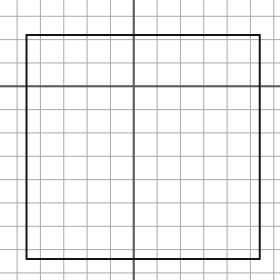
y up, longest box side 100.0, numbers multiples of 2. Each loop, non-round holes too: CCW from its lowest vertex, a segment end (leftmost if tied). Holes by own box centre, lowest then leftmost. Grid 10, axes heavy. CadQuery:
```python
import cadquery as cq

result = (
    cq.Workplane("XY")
    .moveTo(-46.0, -74.0)
    .lineTo(54.0, -74.0)
    .lineTo(54.0, 22.0)
    .lineTo(-46.0, 22.0)
    .close()
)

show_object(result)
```